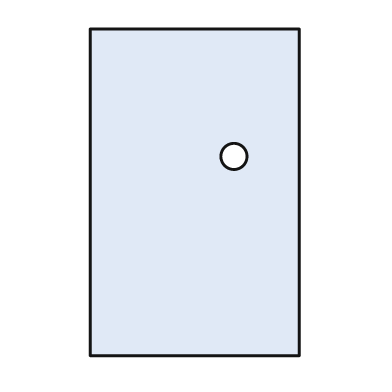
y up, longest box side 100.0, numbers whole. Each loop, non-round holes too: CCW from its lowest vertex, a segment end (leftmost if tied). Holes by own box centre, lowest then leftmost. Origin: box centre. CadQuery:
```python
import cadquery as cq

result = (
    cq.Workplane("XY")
    .moveTo(-32.0, -50.0)
    .lineTo(32.0, -50.0)
    .lineTo(32.0, 50.0)
    .lineTo(-32.0, 50.0)
    .close()
    .moveTo(12.0, 11.0)
    .circle(4.0)
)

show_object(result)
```